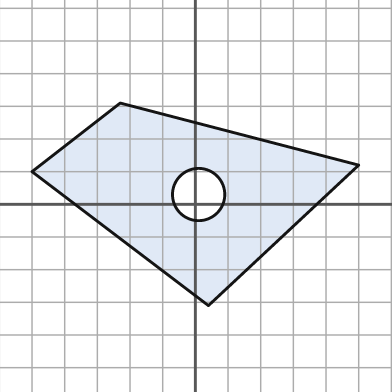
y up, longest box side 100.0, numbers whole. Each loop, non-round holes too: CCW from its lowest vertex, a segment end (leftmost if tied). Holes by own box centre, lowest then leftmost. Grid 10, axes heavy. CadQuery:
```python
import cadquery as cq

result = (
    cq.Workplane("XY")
    .moveTo(4.0, -31.0)
    .lineTo(50.0, 12.0)
    .lineTo(-23.0, 31.0)
    .lineTo(-50.0, 10.0)
    .close()
    .moveTo(1.0, 3.0)
    .circle(8.0)
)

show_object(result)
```